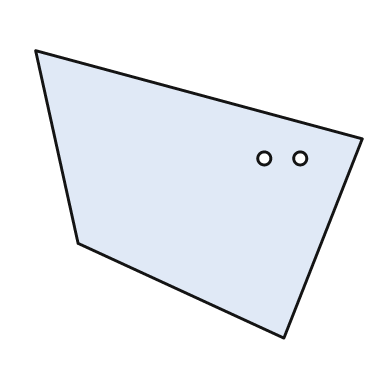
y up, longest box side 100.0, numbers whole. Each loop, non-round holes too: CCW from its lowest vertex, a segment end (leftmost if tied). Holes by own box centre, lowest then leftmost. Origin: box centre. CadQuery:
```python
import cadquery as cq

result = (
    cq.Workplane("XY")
    .moveTo(26.0, -44.0)
    .lineTo(50.0, 17.0)
    .lineTo(-50.0, 44.0)
    .lineTo(-37.0, -15.0)
    .close()
    .moveTo(20.0, 11.0)
    .circle(2.0)
    .moveTo(31.0, 11.0)
    .circle(2.0)
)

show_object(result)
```